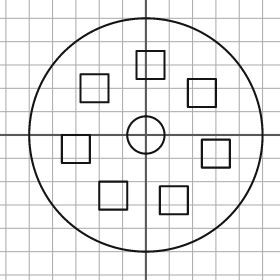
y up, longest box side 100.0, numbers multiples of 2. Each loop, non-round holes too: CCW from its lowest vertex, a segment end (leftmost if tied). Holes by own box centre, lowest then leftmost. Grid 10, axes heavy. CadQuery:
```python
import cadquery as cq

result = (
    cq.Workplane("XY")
    .moveTo(0.0, 0.0)
    .circle(50.0)
    .moveTo(6.0, -34.0)
    .lineTo(18.0, -34.0)
    .lineTo(18.0, -22.0)
    .lineTo(6.0, -22.0)
    .close()
    .moveTo(-20.0, -32.0)
    .lineTo(-8.0, -32.0)
    .lineTo(-8.0, -20.0)
    .lineTo(-20.0, -20.0)
    .close()
    .moveTo(24.0, -14.0)
    .lineTo(36.0, -14.0)
    .lineTo(36.0, -2.0)
    .lineTo(24.0, -2.0)
    .close()
    .moveTo(-36.0, -12.0)
    .lineTo(-24.0, -12.0)
    .lineTo(-24.0, 0.0)
    .lineTo(-36.0, 0.0)
    .close()
    .moveTo(0.0, 0.0)
    .circle(8.0)
    .moveTo(18.0, 12.0)
    .lineTo(30.0, 12.0)
    .lineTo(30.0, 24.0)
    .lineTo(18.0, 24.0)
    .close()
    .moveTo(-28.0, 14.0)
    .lineTo(-16.0, 14.0)
    .lineTo(-16.0, 26.0)
    .lineTo(-28.0, 26.0)
    .close()
    .moveTo(-4.0, 24.0)
    .lineTo(8.0, 24.0)
    .lineTo(8.0, 36.0)
    .lineTo(-4.0, 36.0)
    .close()
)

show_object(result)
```